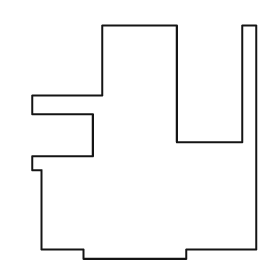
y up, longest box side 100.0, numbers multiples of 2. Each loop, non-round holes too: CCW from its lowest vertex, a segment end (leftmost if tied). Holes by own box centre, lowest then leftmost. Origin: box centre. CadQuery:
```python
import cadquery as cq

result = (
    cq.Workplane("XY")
    .moveTo(-26.0, -50.0)
    .lineTo(18.0, -50.0)
    .lineTo(18.0, -46.0)
    .lineTo(48.0, -46.0)
    .lineTo(48.0, 50.0)
    .lineTo(42.0, 50.0)
    .lineTo(42.0, 0.0)
    .lineTo(14.0, 0.0)
    .lineTo(14.0, 50.0)
    .lineTo(-18.0, 50.0)
    .lineTo(-18.0, 20.0)
    .lineTo(-48.0, 20.0)
    .lineTo(-48.0, 12.0)
    .lineTo(-22.0, 12.0)
    .lineTo(-22.0, -6.0)
    .lineTo(-48.0, -6.0)
    .lineTo(-48.0, -12.0)
    .lineTo(-44.0, -12.0)
    .lineTo(-44.0, -46.0)
    .lineTo(-26.0, -46.0)
    .close()
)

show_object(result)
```